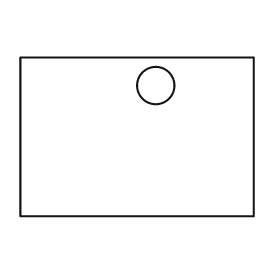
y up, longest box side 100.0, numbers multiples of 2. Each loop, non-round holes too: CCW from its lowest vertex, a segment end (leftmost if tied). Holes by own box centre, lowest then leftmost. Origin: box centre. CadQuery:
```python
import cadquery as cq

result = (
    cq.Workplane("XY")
    .moveTo(-50.0, -34.0)
    .lineTo(50.0, -34.0)
    .lineTo(50.0, 34.0)
    .lineTo(-50.0, 34.0)
    .close()
    .moveTo(8.0, 22.0)
    .circle(8.0)
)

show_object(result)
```